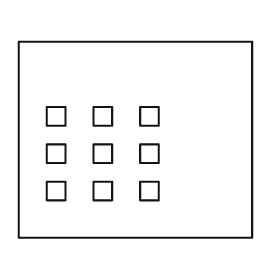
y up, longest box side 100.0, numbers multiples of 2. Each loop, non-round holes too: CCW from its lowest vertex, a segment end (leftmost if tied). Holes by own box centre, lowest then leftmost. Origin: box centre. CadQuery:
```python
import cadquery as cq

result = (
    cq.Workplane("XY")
    .moveTo(-50.0, -42.0)
    .lineTo(50.0, -42.0)
    .lineTo(50.0, 42.0)
    .lineTo(-50.0, 42.0)
    .close()
    .moveTo(-38.0, -26.0)
    .lineTo(-30.0, -26.0)
    .lineTo(-30.0, -18.0)
    .lineTo(-38.0, -18.0)
    .close()
    .moveTo(-18.0, -26.0)
    .lineTo(-10.0, -26.0)
    .lineTo(-10.0, -18.0)
    .lineTo(-18.0, -18.0)
    .close()
    .moveTo(2.0, -26.0)
    .lineTo(10.0, -26.0)
    .lineTo(10.0, -18.0)
    .lineTo(2.0, -18.0)
    .close()
    .moveTo(-38.0, -10.0)
    .lineTo(-30.0, -10.0)
    .lineTo(-30.0, -2.0)
    .lineTo(-38.0, -2.0)
    .close()
    .moveTo(-18.0, -10.0)
    .lineTo(-10.0, -10.0)
    .lineTo(-10.0, -2.0)
    .lineTo(-18.0, -2.0)
    .close()
    .moveTo(2.0, -10.0)
    .lineTo(10.0, -10.0)
    .lineTo(10.0, -2.0)
    .lineTo(2.0, -2.0)
    .close()
    .moveTo(-38.0, 6.0)
    .lineTo(-30.0, 6.0)
    .lineTo(-30.0, 14.0)
    .lineTo(-38.0, 14.0)
    .close()
    .moveTo(-18.0, 6.0)
    .lineTo(-10.0, 6.0)
    .lineTo(-10.0, 14.0)
    .lineTo(-18.0, 14.0)
    .close()
    .moveTo(2.0, 6.0)
    .lineTo(10.0, 6.0)
    .lineTo(10.0, 14.0)
    .lineTo(2.0, 14.0)
    .close()
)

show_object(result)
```